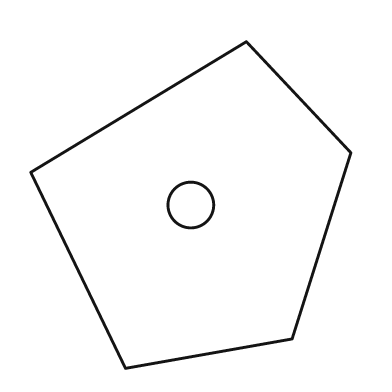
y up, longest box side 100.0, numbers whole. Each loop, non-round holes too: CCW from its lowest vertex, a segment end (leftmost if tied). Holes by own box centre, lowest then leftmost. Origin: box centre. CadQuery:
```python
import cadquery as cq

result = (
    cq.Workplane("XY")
    .moveTo(-20.0, -50.0)
    .lineTo(31.0, -41.0)
    .lineTo(49.0, 16.0)
    .lineTo(17.0, 50.0)
    .lineTo(-49.0, 10.0)
    .close()
    .moveTo(0.0, 0.0)
    .circle(7.0)
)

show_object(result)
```